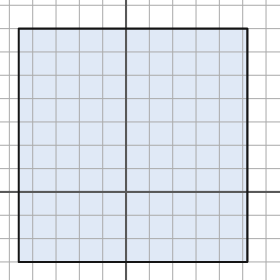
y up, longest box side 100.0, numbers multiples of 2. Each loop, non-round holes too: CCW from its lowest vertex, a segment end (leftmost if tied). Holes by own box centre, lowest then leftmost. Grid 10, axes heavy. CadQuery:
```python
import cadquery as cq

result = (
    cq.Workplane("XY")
    .moveTo(-46.0, -30.0)
    .lineTo(52.0, -30.0)
    .lineTo(52.0, 70.0)
    .lineTo(-46.0, 70.0)
    .close()
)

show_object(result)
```